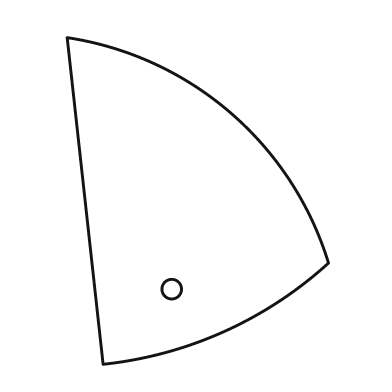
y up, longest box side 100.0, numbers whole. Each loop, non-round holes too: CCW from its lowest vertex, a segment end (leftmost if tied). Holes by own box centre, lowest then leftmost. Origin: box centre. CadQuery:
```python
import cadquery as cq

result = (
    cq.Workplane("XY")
    .moveTo(-29.0, -50.0)
    .threePointArc((8.0, -40.0), (40.0, -19.0))
    .threePointArc((10.0, 27.0), (-40.0, 50.0))
    .close()
    .moveTo(-8.0, -27.0)
    .circle(3.0)
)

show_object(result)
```